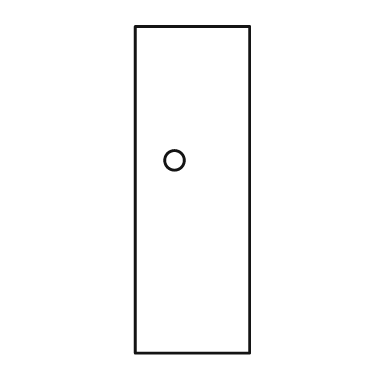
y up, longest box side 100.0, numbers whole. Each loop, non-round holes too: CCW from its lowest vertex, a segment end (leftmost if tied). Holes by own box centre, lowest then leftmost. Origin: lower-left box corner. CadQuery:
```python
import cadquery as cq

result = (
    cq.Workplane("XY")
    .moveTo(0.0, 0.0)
    .lineTo(35.0, 0.0)
    .lineTo(35.0, 100.0)
    .lineTo(0.0, 100.0)
    .close()
    .moveTo(12.0, 59.0)
    .circle(3.0)
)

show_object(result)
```